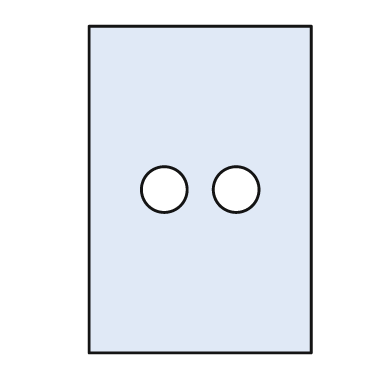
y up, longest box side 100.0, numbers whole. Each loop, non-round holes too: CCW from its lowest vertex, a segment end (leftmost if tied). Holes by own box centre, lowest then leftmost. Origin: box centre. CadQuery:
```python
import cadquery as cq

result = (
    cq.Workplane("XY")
    .moveTo(-34.0, -50.0)
    .lineTo(34.0, -50.0)
    .lineTo(34.0, 50.0)
    .lineTo(-34.0, 50.0)
    .close()
    .moveTo(-11.0, 0.0)
    .circle(7.0)
    .moveTo(11.0, 0.0)
    .circle(7.0)
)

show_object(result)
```